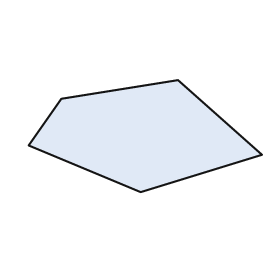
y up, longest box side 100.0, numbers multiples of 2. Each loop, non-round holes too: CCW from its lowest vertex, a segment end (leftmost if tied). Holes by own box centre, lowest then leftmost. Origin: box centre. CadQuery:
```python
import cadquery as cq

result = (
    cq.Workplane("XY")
    .moveTo(-2.0, -24.0)
    .lineTo(50.0, -8.0)
    .lineTo(14.0, 24.0)
    .lineTo(-36.0, 16.0)
    .lineTo(-50.0, -4.0)
    .close()
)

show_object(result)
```